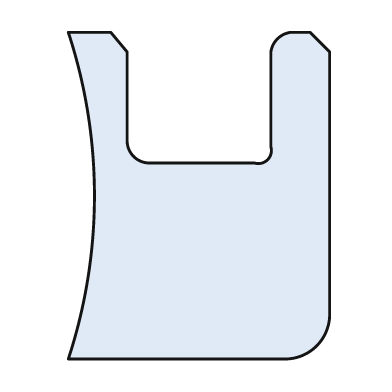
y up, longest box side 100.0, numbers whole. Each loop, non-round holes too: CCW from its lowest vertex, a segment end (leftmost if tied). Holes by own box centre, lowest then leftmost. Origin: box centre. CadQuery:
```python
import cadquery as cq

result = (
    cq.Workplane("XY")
    .moveTo(-40.0, -50.0)
    .lineTo(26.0, -50.0)
    .threePointArc((36.0, -46.0), (40.0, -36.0))
    .lineTo(40.0, 44.0)
    .lineTo(34.0, 50.0)
    .lineTo(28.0, 50.0)
    .threePointArc((24.0, 48.0), (22.0, 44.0))
    .lineTo(22.0, 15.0)
    .threePointArc((21.0, 11.0), (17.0, 10.0))
    .lineTo(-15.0, 10.0)
    .threePointArc((-20.0, 12.0), (-22.0, 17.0))
    .lineTo(-22.0, 44.0)
    .lineTo(-27.0, 50.0)
    .lineTo(-40.0, 50.0)
    .threePointArc((-32.0, 0.0), (-40.0, -50.0))
    .close()
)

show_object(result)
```